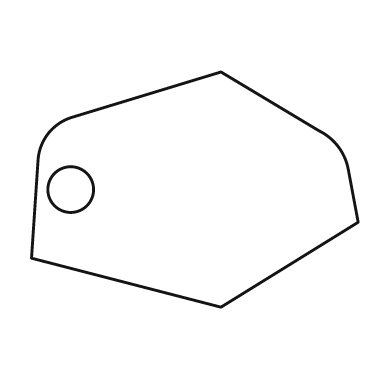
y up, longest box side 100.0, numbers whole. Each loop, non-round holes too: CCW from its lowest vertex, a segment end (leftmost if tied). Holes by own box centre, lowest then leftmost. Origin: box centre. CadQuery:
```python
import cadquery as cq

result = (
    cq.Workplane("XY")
    .moveTo(8.0, -36.0)
    .lineTo(50.0, -10.0)
    .lineTo(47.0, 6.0)
    .threePointArc((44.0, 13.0), (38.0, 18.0))
    .lineTo(8.0, 36.0)
    .lineTo(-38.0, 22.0)
    .threePointArc((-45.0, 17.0), (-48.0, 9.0))
    .lineTo(-50.0, -21.0)
    .close()
    .moveTo(-38.0, 0.0)
    .circle(7.0)
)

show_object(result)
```